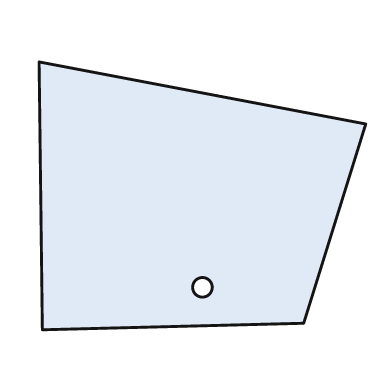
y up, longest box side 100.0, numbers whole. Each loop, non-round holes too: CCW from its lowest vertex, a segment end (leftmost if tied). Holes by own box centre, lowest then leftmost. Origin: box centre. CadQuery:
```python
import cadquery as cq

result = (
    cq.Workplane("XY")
    .moveTo(-49.0, -41.0)
    .lineTo(31.0, -39.0)
    .lineTo(50.0, 22.0)
    .lineTo(-50.0, 41.0)
    .close()
    .moveTo(0.0, -28.0)
    .circle(3.0)
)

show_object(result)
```